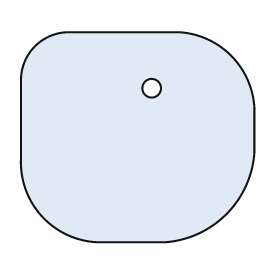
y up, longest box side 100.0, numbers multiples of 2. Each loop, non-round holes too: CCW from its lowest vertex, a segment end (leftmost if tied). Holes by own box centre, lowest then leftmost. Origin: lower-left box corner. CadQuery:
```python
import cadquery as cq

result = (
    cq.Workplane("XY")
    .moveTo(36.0, 0.0)
    .lineTo(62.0, 0.0)
    .threePointArc((88.0, 12.0), (100.0, 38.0))
    .lineTo(100.0, 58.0)
    .threePointArc((90.0, 80.0), (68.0, 90.0))
    .lineTo(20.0, 90.0)
    .threePointArc((6.0, 84.0), (0.0, 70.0))
    .lineTo(0.0, 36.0)
    .threePointArc((10.0, 10.0), (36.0, 0.0))
    .close()
    .moveTo(56.0, 66.0)
    .circle(4.0)
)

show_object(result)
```